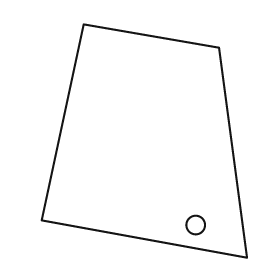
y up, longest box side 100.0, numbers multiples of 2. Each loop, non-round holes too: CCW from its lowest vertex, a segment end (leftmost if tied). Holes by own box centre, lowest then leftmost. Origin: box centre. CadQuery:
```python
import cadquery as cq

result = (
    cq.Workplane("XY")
    .moveTo(44.0, -50.0)
    .lineTo(32.0, 40.0)
    .lineTo(-26.0, 50.0)
    .lineTo(-44.0, -34.0)
    .close()
    .moveTo(22.0, -36.0)
    .circle(4.0)
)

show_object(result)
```